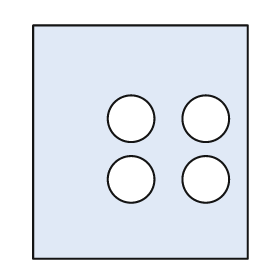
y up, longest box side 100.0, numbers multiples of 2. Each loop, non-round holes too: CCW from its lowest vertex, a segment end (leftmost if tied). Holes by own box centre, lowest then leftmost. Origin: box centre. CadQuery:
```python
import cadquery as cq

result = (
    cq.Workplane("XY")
    .moveTo(-46.0, -50.0)
    .lineTo(46.0, -50.0)
    .lineTo(46.0, 50.0)
    .lineTo(-46.0, 50.0)
    .close()
    .moveTo(-4.0, -16.0)
    .circle(10.0)
    .moveTo(28.0, -16.0)
    .circle(10.0)
    .moveTo(-4.0, 10.0)
    .circle(10.0)
    .moveTo(28.0, 10.0)
    .circle(10.0)
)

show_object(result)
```